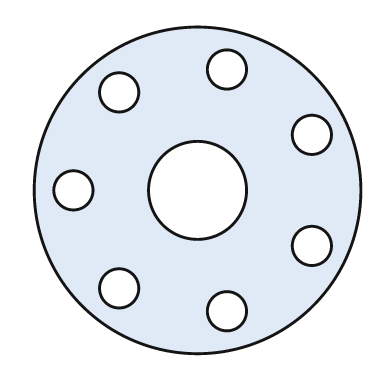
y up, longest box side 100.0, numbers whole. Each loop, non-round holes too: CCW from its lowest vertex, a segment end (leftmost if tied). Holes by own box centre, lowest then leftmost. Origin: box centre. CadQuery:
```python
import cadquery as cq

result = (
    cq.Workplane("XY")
    .moveTo(0.0, 0.0)
    .circle(50.0)
    .moveTo(9.0, -37.0)
    .circle(6.0)
    .moveTo(-24.0, -30.0)
    .circle(6.0)
    .moveTo(35.0, -17.0)
    .circle(6.0)
    .moveTo(-38.0, 0.0)
    .circle(6.0)
    .moveTo(0.0, 0.0)
    .circle(15.0)
    .moveTo(35.0, 17.0)
    .circle(6.0)
    .moveTo(-24.0, 30.0)
    .circle(6.0)
    .moveTo(9.0, 37.0)
    .circle(6.0)
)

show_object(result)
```